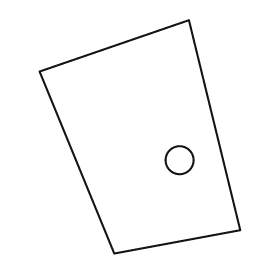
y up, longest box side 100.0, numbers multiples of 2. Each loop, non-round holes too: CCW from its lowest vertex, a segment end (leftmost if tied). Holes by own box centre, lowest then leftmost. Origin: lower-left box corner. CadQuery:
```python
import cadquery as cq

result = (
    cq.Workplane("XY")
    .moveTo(32.0, 0.0)
    .lineTo(86.0, 10.0)
    .lineTo(64.0, 100.0)
    .lineTo(0.0, 78.0)
    .close()
    .moveTo(60.0, 40.0)
    .circle(6.0)
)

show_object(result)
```